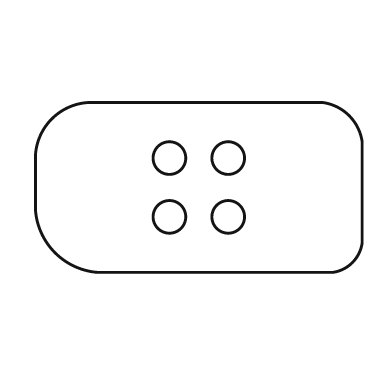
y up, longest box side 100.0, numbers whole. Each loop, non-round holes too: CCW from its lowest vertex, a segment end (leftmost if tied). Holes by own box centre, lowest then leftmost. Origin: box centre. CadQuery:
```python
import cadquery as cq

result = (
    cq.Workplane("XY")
    .moveTo(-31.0, -26.0)
    .lineTo(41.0, -26.0)
    .threePointArc((47.0, -23.0), (50.0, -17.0))
    .lineTo(50.0, 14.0)
    .threePointArc((46.0, 22.0), (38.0, 26.0))
    .lineTo(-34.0, 26.0)
    .threePointArc((-45.0, 21.0), (-50.0, 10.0))
    .lineTo(-50.0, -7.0)
    .threePointArc((-44.0, -20.0), (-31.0, -26.0))
    .close()
    .moveTo(-9.0, -9.0)
    .circle(5.0)
    .moveTo(9.0, -9.0)
    .circle(5.0)
    .moveTo(-9.0, 9.0)
    .circle(5.0)
    .moveTo(9.0, 9.0)
    .circle(5.0)
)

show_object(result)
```